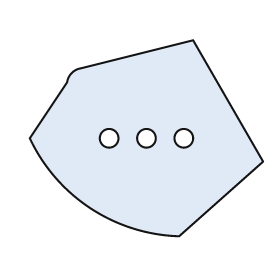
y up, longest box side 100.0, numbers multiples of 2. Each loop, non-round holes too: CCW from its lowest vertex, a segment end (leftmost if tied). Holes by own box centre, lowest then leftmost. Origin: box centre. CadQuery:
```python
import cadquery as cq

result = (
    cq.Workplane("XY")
    .moveTo(14.0, -42.0)
    .lineTo(50.0, -10.0)
    .lineTo(20.0, 42.0)
    .lineTo(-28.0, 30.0)
    .threePointArc((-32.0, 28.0), (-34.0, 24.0))
    .lineTo(-50.0, 0.0)
    .threePointArc((-24.0, -30.0), (14.0, -42.0))
    .close()
    .moveTo(-16.0, 0.0)
    .circle(4.0)
    .moveTo(0.0, 0.0)
    .circle(4.0)
    .moveTo(16.0, 0.0)
    .circle(4.0)
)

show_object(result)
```